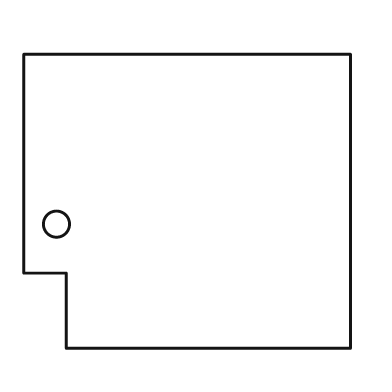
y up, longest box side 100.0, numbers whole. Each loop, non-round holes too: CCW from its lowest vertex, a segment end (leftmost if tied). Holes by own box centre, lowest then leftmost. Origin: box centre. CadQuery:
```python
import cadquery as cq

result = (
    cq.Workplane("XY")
    .moveTo(-37.0, -45.0)
    .lineTo(50.0, -45.0)
    .lineTo(50.0, 45.0)
    .lineTo(-50.0, 45.0)
    .lineTo(-50.0, -22.0)
    .lineTo(-37.0, -22.0)
    .close()
    .moveTo(-40.0, -7.0)
    .circle(4.0)
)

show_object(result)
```